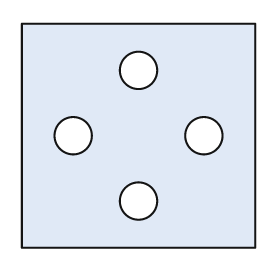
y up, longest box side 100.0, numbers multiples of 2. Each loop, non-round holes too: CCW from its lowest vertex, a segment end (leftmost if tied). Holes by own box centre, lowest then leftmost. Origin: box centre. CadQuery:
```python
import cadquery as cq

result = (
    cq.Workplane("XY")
    .moveTo(-50.0, -48.0)
    .lineTo(50.0, -48.0)
    .lineTo(50.0, 48.0)
    .lineTo(-50.0, 48.0)
    .close()
    .moveTo(0.0, -28.0)
    .circle(8.0)
    .moveTo(-28.0, 0.0)
    .circle(8.0)
    .moveTo(28.0, 0.0)
    .circle(8.0)
    .moveTo(0.0, 28.0)
    .circle(8.0)
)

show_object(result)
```